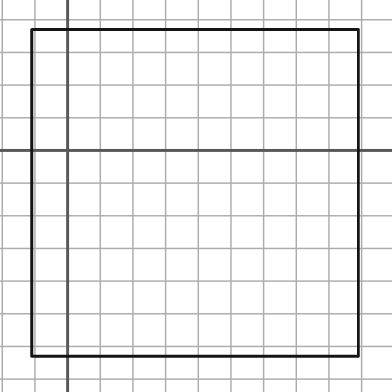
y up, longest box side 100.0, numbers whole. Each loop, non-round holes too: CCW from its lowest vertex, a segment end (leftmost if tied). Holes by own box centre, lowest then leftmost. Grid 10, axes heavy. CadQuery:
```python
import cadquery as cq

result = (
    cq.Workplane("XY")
    .moveTo(-11.0, -63.0)
    .lineTo(89.0, -63.0)
    .lineTo(89.0, 37.0)
    .lineTo(-11.0, 37.0)
    .close()
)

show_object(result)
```